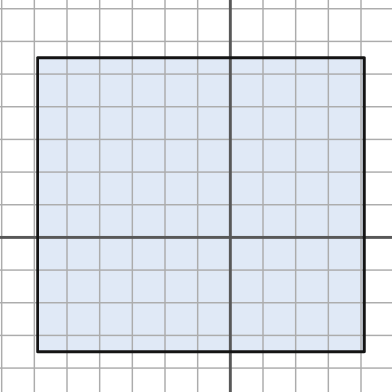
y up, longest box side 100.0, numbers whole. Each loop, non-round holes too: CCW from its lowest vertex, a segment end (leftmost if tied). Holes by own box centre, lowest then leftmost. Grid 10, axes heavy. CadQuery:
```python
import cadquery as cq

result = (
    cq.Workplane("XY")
    .moveTo(-59.0, -35.0)
    .lineTo(41.0, -35.0)
    .lineTo(41.0, 55.0)
    .lineTo(-59.0, 55.0)
    .close()
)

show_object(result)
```